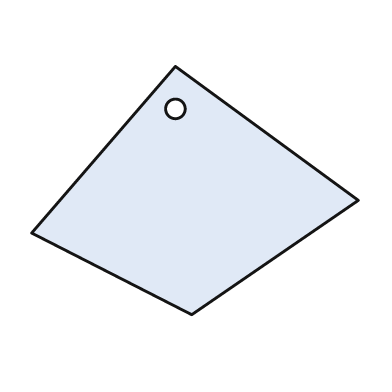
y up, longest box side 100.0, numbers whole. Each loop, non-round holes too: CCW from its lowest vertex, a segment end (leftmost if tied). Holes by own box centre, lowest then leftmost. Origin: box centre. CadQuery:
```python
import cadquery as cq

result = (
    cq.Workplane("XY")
    .moveTo(-1.0, -38.0)
    .lineTo(50.0, -3.0)
    .lineTo(-6.0, 38.0)
    .lineTo(-50.0, -13.0)
    .close()
    .moveTo(-6.0, 25.0)
    .circle(3.0)
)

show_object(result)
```